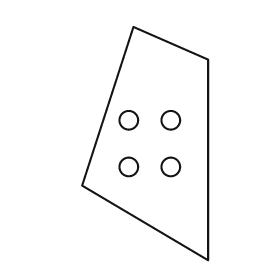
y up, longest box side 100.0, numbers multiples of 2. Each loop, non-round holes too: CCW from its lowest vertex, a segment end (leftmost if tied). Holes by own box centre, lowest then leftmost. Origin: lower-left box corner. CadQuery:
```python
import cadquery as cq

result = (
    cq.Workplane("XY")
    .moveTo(54.0, 0.0)
    .lineTo(54.0, 86.0)
    .lineTo(22.0, 100.0)
    .lineTo(0.0, 32.0)
    .close()
    .moveTo(20.0, 40.0)
    .circle(4.0)
    .moveTo(38.0, 40.0)
    .circle(4.0)
    .moveTo(20.0, 60.0)
    .circle(4.0)
    .moveTo(38.0, 60.0)
    .circle(4.0)
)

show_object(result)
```